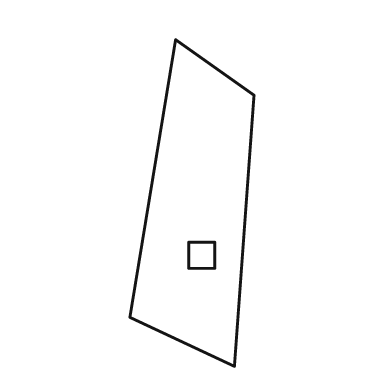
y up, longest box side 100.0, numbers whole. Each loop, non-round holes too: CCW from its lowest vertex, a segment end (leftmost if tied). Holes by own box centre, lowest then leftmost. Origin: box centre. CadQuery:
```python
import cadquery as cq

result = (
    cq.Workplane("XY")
    .moveTo(13.0, -50.0)
    .lineTo(19.0, 33.0)
    .lineTo(-5.0, 50.0)
    .lineTo(-19.0, -35.0)
    .close()
    .moveTo(-1.0, -20.0)
    .lineTo(7.0, -20.0)
    .lineTo(7.0, -12.0)
    .lineTo(-1.0, -12.0)
    .close()
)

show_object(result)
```